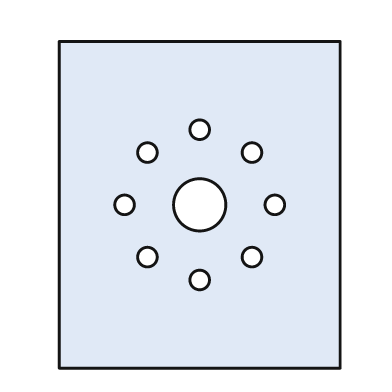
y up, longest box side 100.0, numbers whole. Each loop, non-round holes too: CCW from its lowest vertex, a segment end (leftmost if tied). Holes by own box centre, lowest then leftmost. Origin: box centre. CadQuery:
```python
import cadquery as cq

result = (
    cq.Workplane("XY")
    .moveTo(-43.0, -50.0)
    .lineTo(43.0, -50.0)
    .lineTo(43.0, 50.0)
    .lineTo(-43.0, 50.0)
    .close()
    .moveTo(0.0, -23.0)
    .circle(3.0)
    .moveTo(-16.0, -16.0)
    .circle(3.0)
    .moveTo(16.0, -16.0)
    .circle(3.0)
    .moveTo(-23.0, 0.0)
    .circle(3.0)
    .moveTo(0.0, 0.0)
    .circle(8.0)
    .moveTo(23.0, 0.0)
    .circle(3.0)
    .moveTo(-16.0, 16.0)
    .circle(3.0)
    .moveTo(16.0, 16.0)
    .circle(3.0)
    .moveTo(0.0, 23.0)
    .circle(3.0)
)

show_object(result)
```